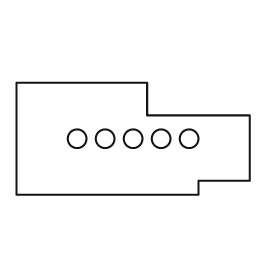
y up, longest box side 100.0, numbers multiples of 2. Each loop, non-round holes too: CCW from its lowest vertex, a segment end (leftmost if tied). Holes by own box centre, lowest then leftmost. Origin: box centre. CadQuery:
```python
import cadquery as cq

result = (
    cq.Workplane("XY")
    .moveTo(-50.0, -24.0)
    .lineTo(28.0, -24.0)
    .lineTo(28.0, -18.0)
    .lineTo(50.0, -18.0)
    .lineTo(50.0, 10.0)
    .lineTo(6.0, 10.0)
    .lineTo(6.0, 24.0)
    .lineTo(-50.0, 24.0)
    .close()
    .moveTo(-24.0, 0.0)
    .circle(4.0)
    .moveTo(-12.0, 0.0)
    .circle(4.0)
    .moveTo(0.0, 0.0)
    .circle(4.0)
    .moveTo(12.0, 0.0)
    .circle(4.0)
    .moveTo(24.0, 0.0)
    .circle(4.0)
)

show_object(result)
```